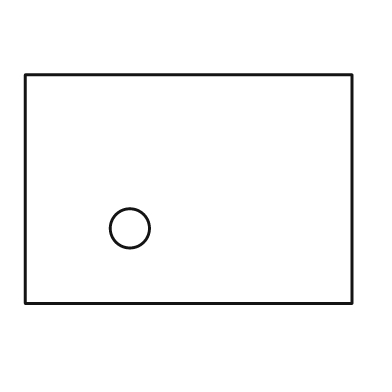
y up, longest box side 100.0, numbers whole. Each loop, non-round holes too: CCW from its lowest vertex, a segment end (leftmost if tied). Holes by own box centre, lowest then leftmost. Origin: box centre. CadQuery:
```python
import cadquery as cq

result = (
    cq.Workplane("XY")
    .moveTo(-50.0, -35.0)
    .lineTo(50.0, -35.0)
    .lineTo(50.0, 35.0)
    .lineTo(-50.0, 35.0)
    .close()
    .moveTo(-18.0, -12.0)
    .circle(6.0)
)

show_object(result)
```